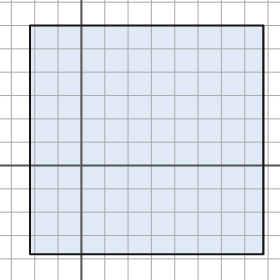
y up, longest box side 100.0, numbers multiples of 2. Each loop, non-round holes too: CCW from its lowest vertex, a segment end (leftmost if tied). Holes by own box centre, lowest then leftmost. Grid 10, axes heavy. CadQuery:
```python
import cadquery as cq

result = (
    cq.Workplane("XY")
    .moveTo(-22.0, -38.0)
    .lineTo(78.0, -38.0)
    .lineTo(78.0, 60.0)
    .lineTo(-22.0, 60.0)
    .close()
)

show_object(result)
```